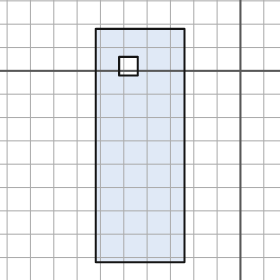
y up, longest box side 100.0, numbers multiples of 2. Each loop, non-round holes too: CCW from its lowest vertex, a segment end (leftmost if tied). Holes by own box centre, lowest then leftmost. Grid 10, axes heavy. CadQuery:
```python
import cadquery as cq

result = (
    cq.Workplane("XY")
    .moveTo(-62.0, -82.0)
    .lineTo(-24.0, -82.0)
    .lineTo(-24.0, 18.0)
    .lineTo(-62.0, 18.0)
    .close()
    .moveTo(-52.0, -2.0)
    .lineTo(-44.0, -2.0)
    .lineTo(-44.0, 6.0)
    .lineTo(-52.0, 6.0)
    .close()
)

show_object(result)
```